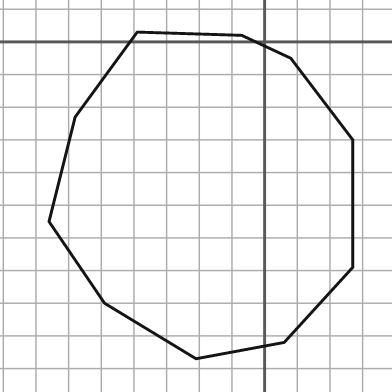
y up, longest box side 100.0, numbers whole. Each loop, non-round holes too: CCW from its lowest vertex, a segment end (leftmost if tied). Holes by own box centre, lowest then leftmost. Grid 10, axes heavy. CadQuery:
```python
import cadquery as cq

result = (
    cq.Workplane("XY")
    .moveTo(-21.0, -97.0)
    .lineTo(6.0, -92.0)
    .lineTo(27.0, -69.0)
    .lineTo(27.0, -30.0)
    .lineTo(8.0, -5.0)
    .lineTo(-7.0, 2.0)
    .lineTo(-39.0, 3.0)
    .lineTo(-58.0, -23.0)
    .lineTo(-66.0, -55.0)
    .lineTo(-49.0, -80.0)
    .close()
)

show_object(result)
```